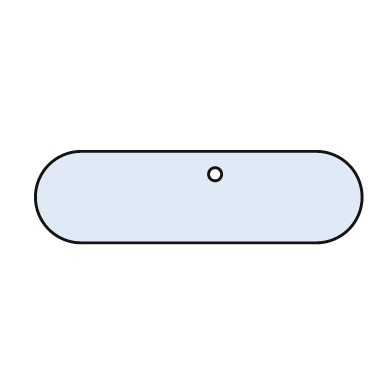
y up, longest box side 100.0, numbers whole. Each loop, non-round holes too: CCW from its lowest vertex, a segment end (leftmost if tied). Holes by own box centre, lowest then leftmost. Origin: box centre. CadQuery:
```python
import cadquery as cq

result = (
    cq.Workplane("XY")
    .moveTo(-36.0, -14.0)
    .lineTo(36.0, -14.0)
    .threePointArc((50.0, 0.0), (36.0, 14.0))
    .lineTo(-36.0, 14.0)
    .threePointArc((-50.0, 0.0), (-36.0, -14.0))
    .close()
    .moveTo(5.0, 7.0)
    .circle(2.0)
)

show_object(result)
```